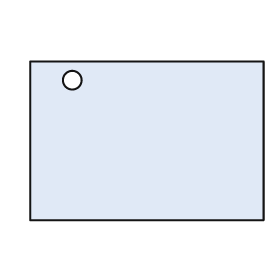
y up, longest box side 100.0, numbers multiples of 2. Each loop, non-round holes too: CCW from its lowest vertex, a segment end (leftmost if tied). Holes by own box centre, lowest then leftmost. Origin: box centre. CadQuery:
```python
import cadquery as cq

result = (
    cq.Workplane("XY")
    .moveTo(-50.0, -34.0)
    .lineTo(50.0, -34.0)
    .lineTo(50.0, 34.0)
    .lineTo(-50.0, 34.0)
    .close()
    .moveTo(-32.0, 26.0)
    .circle(4.0)
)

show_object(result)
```